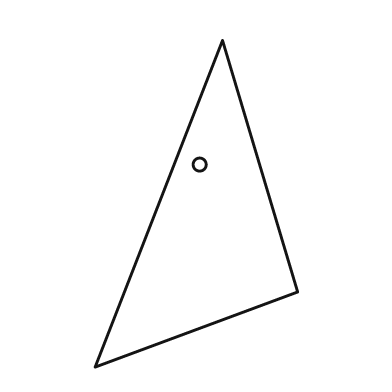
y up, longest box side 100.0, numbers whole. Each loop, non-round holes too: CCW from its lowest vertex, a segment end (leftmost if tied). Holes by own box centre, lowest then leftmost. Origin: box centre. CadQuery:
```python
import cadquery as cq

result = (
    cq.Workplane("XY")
    .moveTo(-31.0, -50.0)
    .lineTo(31.0, -27.0)
    .lineTo(8.0, 50.0)
    .close()
    .moveTo(1.0, 12.0)
    .circle(2.0)
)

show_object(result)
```